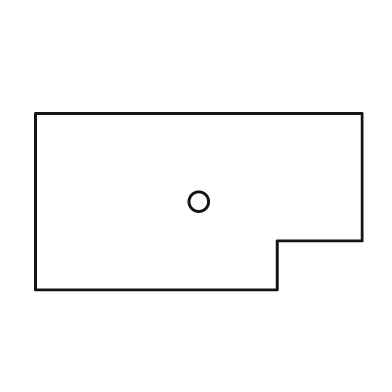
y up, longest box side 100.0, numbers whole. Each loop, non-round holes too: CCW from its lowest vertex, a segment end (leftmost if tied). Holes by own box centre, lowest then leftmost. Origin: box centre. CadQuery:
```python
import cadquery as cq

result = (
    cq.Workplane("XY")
    .moveTo(-50.0, -27.0)
    .lineTo(24.0, -27.0)
    .lineTo(24.0, -12.0)
    .lineTo(50.0, -12.0)
    .lineTo(50.0, 27.0)
    .lineTo(-50.0, 27.0)
    .close()
    .moveTo(0.0, 0.0)
    .circle(3.0)
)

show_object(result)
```